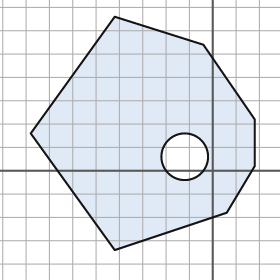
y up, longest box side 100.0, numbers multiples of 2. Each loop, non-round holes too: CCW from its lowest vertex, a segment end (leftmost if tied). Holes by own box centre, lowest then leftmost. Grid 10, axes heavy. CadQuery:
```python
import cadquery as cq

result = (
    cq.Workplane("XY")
    .moveTo(-42.0, -34.0)
    .lineTo(6.0, -18.0)
    .lineTo(18.0, 2.0)
    .lineTo(18.0, 22.0)
    .lineTo(-4.0, 54.0)
    .lineTo(-42.0, 66.0)
    .lineTo(-78.0, 16.0)
    .close()
    .moveTo(-12.0, 6.0)
    .circle(10.0)
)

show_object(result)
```